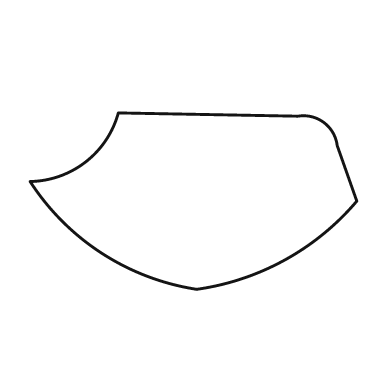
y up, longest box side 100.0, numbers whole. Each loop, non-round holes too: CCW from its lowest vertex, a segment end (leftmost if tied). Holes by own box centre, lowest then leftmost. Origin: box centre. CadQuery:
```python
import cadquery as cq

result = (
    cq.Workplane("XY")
    .moveTo(1.0, -27.0)
    .threePointArc((28.0, -18.0), (50.0, 0.0))
    .lineTo(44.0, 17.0)
    .threePointArc((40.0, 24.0), (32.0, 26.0))
    .lineTo(-23.0, 27.0)
    .threePointArc((-33.0, 12.0), (-50.0, 6.0))
    .threePointArc((-28.0, -16.0), (1.0, -27.0))
    .close()
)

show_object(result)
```